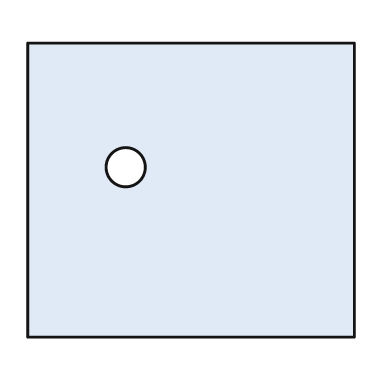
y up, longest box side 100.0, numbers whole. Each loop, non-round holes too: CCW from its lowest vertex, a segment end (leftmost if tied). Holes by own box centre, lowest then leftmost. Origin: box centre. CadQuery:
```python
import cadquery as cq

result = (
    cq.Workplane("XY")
    .moveTo(-50.0, -45.0)
    .lineTo(50.0, -45.0)
    .lineTo(50.0, 45.0)
    .lineTo(-50.0, 45.0)
    .close()
    .moveTo(-20.0, 7.0)
    .circle(6.0)
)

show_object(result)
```